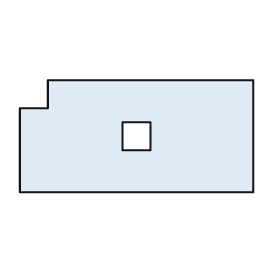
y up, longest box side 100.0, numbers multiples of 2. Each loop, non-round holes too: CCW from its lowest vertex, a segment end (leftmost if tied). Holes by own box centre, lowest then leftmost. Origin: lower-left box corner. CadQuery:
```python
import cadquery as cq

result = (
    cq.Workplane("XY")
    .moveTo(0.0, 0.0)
    .lineTo(100.0, 0.0)
    .lineTo(100.0, 48.0)
    .lineTo(12.0, 48.0)
    .lineTo(12.0, 36.0)
    .lineTo(0.0, 36.0)
    .close()
    .moveTo(44.0, 18.0)
    .lineTo(56.0, 18.0)
    .lineTo(56.0, 30.0)
    .lineTo(44.0, 30.0)
    .close()
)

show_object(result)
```